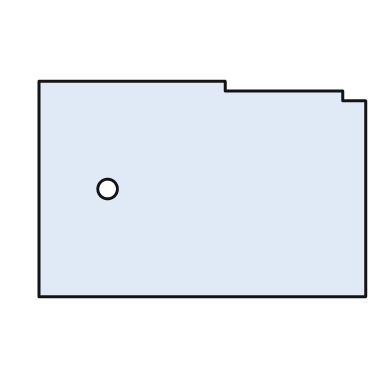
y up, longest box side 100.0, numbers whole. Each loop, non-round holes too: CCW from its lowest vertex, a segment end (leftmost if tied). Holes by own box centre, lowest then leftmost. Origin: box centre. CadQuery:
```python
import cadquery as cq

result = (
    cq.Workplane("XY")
    .moveTo(-50.0, -33.0)
    .lineTo(50.0, -33.0)
    .lineTo(50.0, 27.0)
    .lineTo(43.0, 27.0)
    .lineTo(43.0, 30.0)
    .lineTo(7.0, 30.0)
    .lineTo(7.0, 33.0)
    .lineTo(-50.0, 33.0)
    .close()
    .moveTo(-29.0, 0.0)
    .circle(3.0)
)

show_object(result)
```